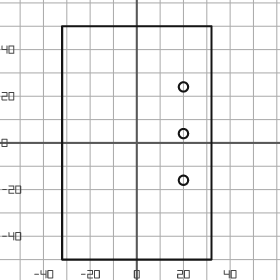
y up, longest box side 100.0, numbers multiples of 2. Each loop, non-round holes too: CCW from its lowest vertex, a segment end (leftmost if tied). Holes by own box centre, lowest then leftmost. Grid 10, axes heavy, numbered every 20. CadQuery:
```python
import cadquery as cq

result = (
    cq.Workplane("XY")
    .moveTo(-32.0, -50.0)
    .lineTo(32.0, -50.0)
    .lineTo(32.0, 50.0)
    .lineTo(-32.0, 50.0)
    .close()
    .moveTo(20.0, -16.0)
    .circle(2.0)
    .moveTo(20.0, 4.0)
    .circle(2.0)
    .moveTo(20.0, 24.0)
    .circle(2.0)
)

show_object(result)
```